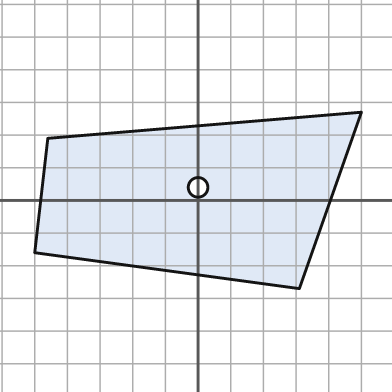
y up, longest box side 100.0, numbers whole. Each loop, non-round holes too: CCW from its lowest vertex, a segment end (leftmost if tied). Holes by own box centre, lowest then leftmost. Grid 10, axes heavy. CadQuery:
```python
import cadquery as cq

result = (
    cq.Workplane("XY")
    .moveTo(31.0, -27.0)
    .lineTo(50.0, 27.0)
    .lineTo(-46.0, 19.0)
    .lineTo(-50.0, -16.0)
    .close()
    .moveTo(0.0, 4.0)
    .circle(3.0)
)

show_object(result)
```